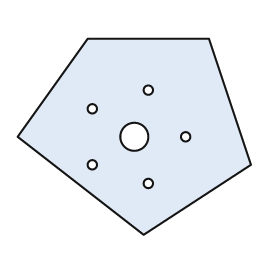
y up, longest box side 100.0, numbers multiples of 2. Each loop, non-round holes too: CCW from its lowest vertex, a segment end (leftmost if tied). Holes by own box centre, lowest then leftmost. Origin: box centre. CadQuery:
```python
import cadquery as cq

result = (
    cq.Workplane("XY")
    .moveTo(4.0, -42.0)
    .lineTo(50.0, -12.0)
    .lineTo(32.0, 42.0)
    .lineTo(-20.0, 42.0)
    .lineTo(-50.0, 0.0)
    .close()
    .moveTo(6.0, -20.0)
    .circle(2.0)
    .moveTo(-18.0, -12.0)
    .circle(2.0)
    .moveTo(0.0, 0.0)
    .circle(6.0)
    .moveTo(22.0, 0.0)
    .circle(2.0)
    .moveTo(-18.0, 12.0)
    .circle(2.0)
    .moveTo(6.0, 20.0)
    .circle(2.0)
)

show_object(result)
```